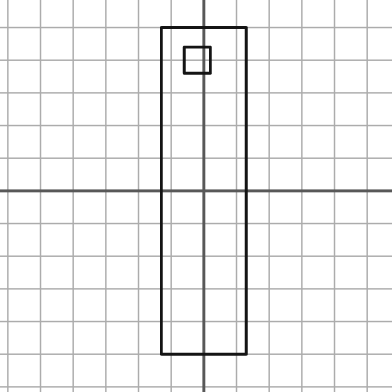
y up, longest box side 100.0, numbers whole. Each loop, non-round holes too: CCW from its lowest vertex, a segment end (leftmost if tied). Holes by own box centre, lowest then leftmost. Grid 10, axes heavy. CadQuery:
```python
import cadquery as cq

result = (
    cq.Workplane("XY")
    .moveTo(-13.0, -50.0)
    .lineTo(13.0, -50.0)
    .lineTo(13.0, 50.0)
    .lineTo(-13.0, 50.0)
    .close()
    .moveTo(-6.0, 36.0)
    .lineTo(2.0, 36.0)
    .lineTo(2.0, 44.0)
    .lineTo(-6.0, 44.0)
    .close()
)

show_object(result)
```